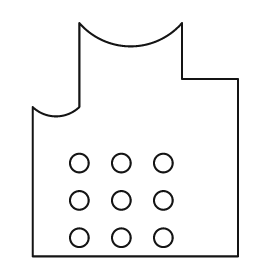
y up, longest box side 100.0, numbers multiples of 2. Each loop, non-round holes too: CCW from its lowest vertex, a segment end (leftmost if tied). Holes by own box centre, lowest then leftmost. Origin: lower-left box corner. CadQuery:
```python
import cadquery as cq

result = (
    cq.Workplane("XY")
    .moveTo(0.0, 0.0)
    .lineTo(88.0, 0.0)
    .lineTo(88.0, 76.0)
    .lineTo(64.0, 76.0)
    .lineTo(64.0, 100.0)
    .threePointArc((42.0, 90.0), (20.0, 100.0))
    .lineTo(20.0, 64.0)
    .threePointArc((10.0, 60.0), (0.0, 64.0))
    .close()
    .moveTo(20.0, 8.0)
    .circle(4.0)
    .moveTo(38.0, 8.0)
    .circle(4.0)
    .moveTo(56.0, 8.0)
    .circle(4.0)
    .moveTo(20.0, 24.0)
    .circle(4.0)
    .moveTo(38.0, 24.0)
    .circle(4.0)
    .moveTo(56.0, 24.0)
    .circle(4.0)
    .moveTo(20.0, 40.0)
    .circle(4.0)
    .moveTo(38.0, 40.0)
    .circle(4.0)
    .moveTo(56.0, 40.0)
    .circle(4.0)
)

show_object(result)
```